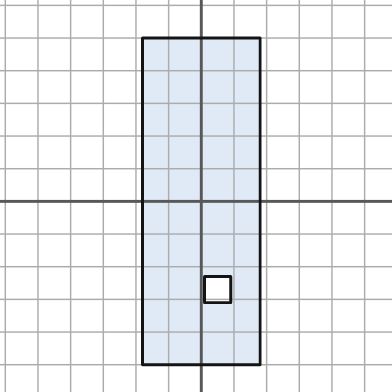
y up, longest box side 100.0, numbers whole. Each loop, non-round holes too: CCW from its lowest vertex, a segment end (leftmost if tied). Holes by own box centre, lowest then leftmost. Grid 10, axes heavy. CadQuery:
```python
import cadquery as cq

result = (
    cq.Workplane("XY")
    .moveTo(-18.0, -50.0)
    .lineTo(18.0, -50.0)
    .lineTo(18.0, 50.0)
    .lineTo(-18.0, 50.0)
    .close()
    .moveTo(1.0, -31.0)
    .lineTo(9.0, -31.0)
    .lineTo(9.0, -23.0)
    .lineTo(1.0, -23.0)
    .close()
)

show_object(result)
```